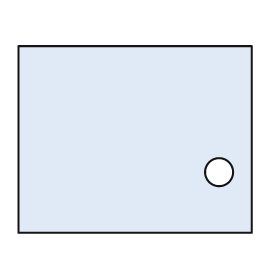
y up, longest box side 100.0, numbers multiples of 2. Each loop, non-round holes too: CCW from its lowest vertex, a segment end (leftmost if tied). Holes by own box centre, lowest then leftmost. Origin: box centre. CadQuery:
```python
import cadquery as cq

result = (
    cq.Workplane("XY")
    .moveTo(-50.0, -40.0)
    .lineTo(50.0, -40.0)
    .lineTo(50.0, 40.0)
    .lineTo(-50.0, 40.0)
    .close()
    .moveTo(36.0, -14.0)
    .circle(6.0)
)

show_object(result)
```